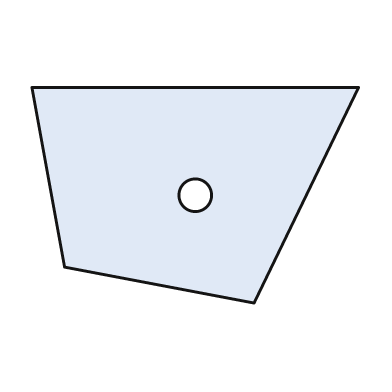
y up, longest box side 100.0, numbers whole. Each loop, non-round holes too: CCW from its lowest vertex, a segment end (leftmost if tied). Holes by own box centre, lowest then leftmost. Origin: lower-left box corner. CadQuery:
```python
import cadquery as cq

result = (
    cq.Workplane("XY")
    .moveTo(68.0, 0.0)
    .lineTo(100.0, 66.0)
    .lineTo(0.0, 66.0)
    .lineTo(10.0, 11.0)
    .close()
    .moveTo(50.0, 33.0)
    .circle(5.0)
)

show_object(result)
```